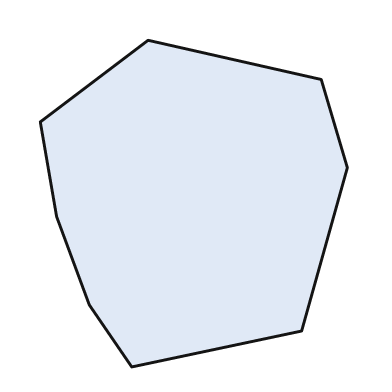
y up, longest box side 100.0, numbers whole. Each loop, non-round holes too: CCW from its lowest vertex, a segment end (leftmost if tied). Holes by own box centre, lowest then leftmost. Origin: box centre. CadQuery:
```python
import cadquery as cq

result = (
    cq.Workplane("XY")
    .moveTo(-19.0, -50.0)
    .lineTo(33.0, -39.0)
    .lineTo(47.0, 11.0)
    .lineTo(39.0, 38.0)
    .lineTo(-14.0, 50.0)
    .lineTo(-47.0, 25.0)
    .lineTo(-42.0, -4.0)
    .lineTo(-32.0, -31.0)
    .close()
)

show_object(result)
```